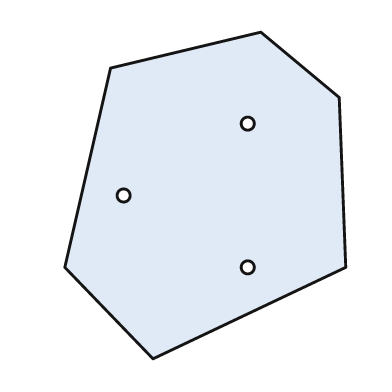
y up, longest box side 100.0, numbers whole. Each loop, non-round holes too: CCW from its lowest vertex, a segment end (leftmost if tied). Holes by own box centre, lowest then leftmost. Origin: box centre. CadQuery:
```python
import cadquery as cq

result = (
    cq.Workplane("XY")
    .moveTo(-16.0, -50.0)
    .lineTo(43.0, -22.0)
    .lineTo(41.0, 30.0)
    .lineTo(17.0, 50.0)
    .lineTo(-29.0, 39.0)
    .lineTo(-43.0, -22.0)
    .close()
    .moveTo(13.0, -22.0)
    .circle(2.0)
    .moveTo(-25.0, 0.0)
    .circle(2.0)
    .moveTo(13.0, 22.0)
    .circle(2.0)
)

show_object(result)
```